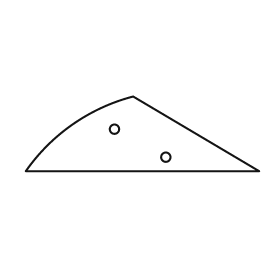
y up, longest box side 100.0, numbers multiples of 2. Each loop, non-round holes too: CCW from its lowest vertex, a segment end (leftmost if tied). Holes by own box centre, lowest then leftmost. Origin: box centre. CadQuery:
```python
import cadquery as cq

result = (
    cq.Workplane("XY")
    .moveTo(-50.0, -16.0)
    .lineTo(50.0, -16.0)
    .lineTo(-4.0, 16.0)
    .threePointArc((-30.0, 4.0), (-50.0, -16.0))
    .close()
    .moveTo(10.0, -10.0)
    .circle(2.0)
    .moveTo(-12.0, 2.0)
    .circle(2.0)
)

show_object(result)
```